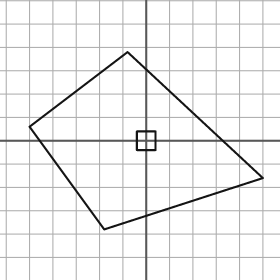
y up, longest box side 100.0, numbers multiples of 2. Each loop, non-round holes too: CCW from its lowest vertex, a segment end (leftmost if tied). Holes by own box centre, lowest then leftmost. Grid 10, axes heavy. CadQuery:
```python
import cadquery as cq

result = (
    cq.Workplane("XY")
    .moveTo(-18.0, -38.0)
    .lineTo(50.0, -16.0)
    .lineTo(-8.0, 38.0)
    .lineTo(-50.0, 6.0)
    .close()
    .moveTo(-4.0, -4.0)
    .lineTo(4.0, -4.0)
    .lineTo(4.0, 4.0)
    .lineTo(-4.0, 4.0)
    .close()
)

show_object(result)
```